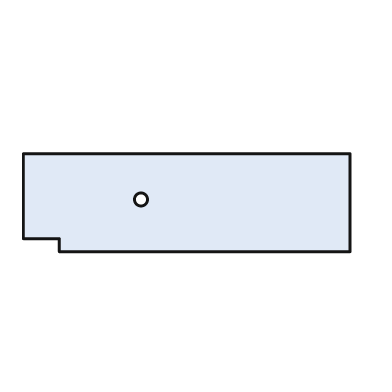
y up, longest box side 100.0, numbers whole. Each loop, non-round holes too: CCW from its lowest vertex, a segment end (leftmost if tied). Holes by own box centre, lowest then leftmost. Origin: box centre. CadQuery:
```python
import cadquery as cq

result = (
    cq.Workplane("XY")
    .moveTo(-39.0, -15.0)
    .lineTo(50.0, -15.0)
    .lineTo(50.0, 15.0)
    .lineTo(-50.0, 15.0)
    .lineTo(-50.0, -11.0)
    .lineTo(-39.0, -11.0)
    .close()
    .moveTo(-14.0, 1.0)
    .circle(2.0)
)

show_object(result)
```